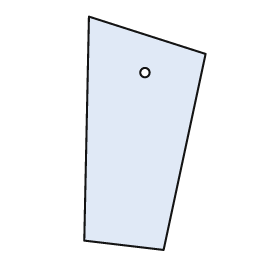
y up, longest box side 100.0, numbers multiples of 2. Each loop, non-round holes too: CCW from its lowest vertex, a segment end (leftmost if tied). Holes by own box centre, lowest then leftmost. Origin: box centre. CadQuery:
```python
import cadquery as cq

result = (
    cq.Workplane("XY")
    .moveTo(8.0, -50.0)
    .lineTo(26.0, 34.0)
    .lineTo(-24.0, 50.0)
    .lineTo(-26.0, -46.0)
    .close()
    .moveTo(0.0, 26.0)
    .circle(2.0)
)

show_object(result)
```